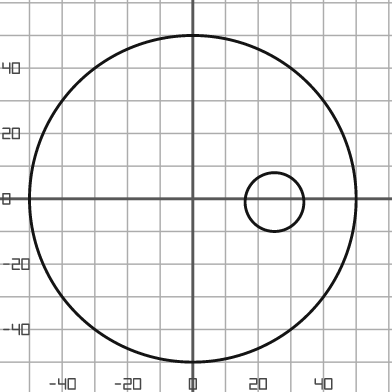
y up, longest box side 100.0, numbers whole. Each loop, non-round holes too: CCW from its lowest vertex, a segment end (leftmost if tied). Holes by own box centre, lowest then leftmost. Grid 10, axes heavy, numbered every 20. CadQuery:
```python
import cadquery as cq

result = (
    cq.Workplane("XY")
    .moveTo(0.0, 0.0)
    .circle(50.0)
    .moveTo(25.0, -1.0)
    .circle(9.0)
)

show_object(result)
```